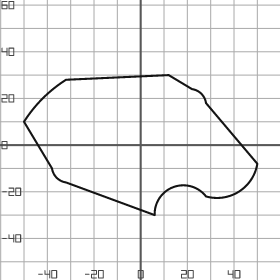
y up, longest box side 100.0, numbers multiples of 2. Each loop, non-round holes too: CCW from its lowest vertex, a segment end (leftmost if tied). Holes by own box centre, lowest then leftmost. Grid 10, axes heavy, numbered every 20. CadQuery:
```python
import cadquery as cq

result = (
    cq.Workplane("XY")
    .moveTo(6.0, -30.0)
    .threePointArc((14.0, -18.0), (28.0, -22.0))
    .threePointArc((42.0, -20.0), (50.0, -8.0))
    .lineTo(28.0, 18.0)
    .threePointArc((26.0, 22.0), (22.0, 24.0))
    .lineTo(12.0, 30.0)
    .lineTo(-32.0, 28.0)
    .threePointArc((-42.0, 20.0), (-50.0, 10.0))
    .lineTo(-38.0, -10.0)
    .threePointArc((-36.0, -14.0), (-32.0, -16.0))
    .close()
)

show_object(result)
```